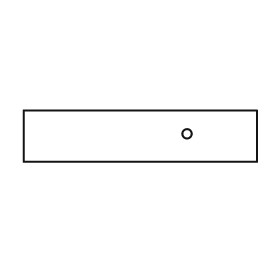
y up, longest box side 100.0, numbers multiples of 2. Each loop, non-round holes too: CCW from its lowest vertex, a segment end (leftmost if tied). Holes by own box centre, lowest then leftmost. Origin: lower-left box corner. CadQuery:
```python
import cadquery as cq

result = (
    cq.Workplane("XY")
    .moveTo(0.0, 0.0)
    .lineTo(100.0, 0.0)
    .lineTo(100.0, 22.0)
    .lineTo(0.0, 22.0)
    .close()
    .moveTo(70.0, 12.0)
    .circle(2.0)
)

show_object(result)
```